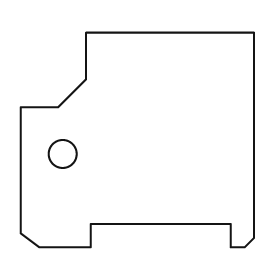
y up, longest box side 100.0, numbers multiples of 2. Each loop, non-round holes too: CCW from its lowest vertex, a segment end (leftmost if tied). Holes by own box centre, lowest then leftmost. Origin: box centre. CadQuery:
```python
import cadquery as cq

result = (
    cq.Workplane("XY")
    .moveTo(-42.0, -46.0)
    .lineTo(-20.0, -46.0)
    .lineTo(-20.0, -36.0)
    .lineTo(40.0, -36.0)
    .lineTo(40.0, -46.0)
    .lineTo(46.0, -46.0)
    .lineTo(50.0, -42.0)
    .lineTo(50.0, 46.0)
    .lineTo(-22.0, 46.0)
    .lineTo(-22.0, 26.0)
    .lineTo(-34.0, 14.0)
    .lineTo(-50.0, 14.0)
    .lineTo(-50.0, -40.0)
    .close()
    .moveTo(-32.0, -6.0)
    .circle(6.0)
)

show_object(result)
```